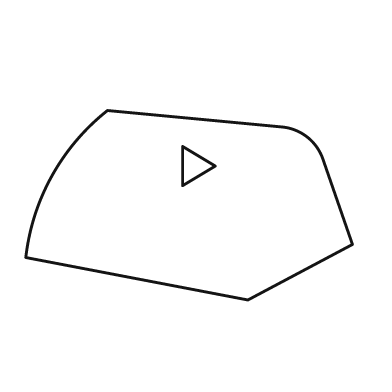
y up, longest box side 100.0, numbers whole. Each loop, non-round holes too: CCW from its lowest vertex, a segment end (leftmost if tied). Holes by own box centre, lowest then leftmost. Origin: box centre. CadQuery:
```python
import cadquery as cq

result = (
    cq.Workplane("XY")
    .moveTo(18.0, -29.0)
    .lineTo(50.0, -12.0)
    .lineTo(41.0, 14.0)
    .threePointArc((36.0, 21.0), (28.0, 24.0))
    .lineTo(-25.0, 29.0)
    .threePointArc((-42.0, 9.0), (-50.0, -16.0))
    .close()
    .moveTo(-2.0, 6.0)
    .lineTo(8.0, 12.0)
    .lineTo(-2.0, 18.0)
    .close()
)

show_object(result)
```